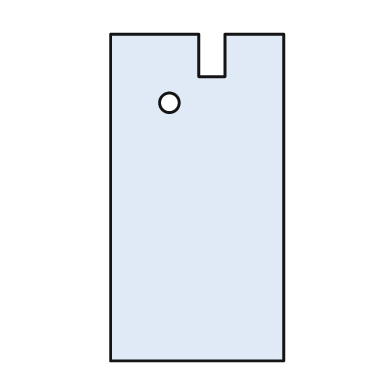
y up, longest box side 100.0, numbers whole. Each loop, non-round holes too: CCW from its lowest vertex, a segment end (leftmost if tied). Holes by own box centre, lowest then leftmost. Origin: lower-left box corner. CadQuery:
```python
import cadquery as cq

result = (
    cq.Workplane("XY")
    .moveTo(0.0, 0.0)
    .lineTo(53.0, 0.0)
    .lineTo(53.0, 100.0)
    .lineTo(35.0, 100.0)
    .lineTo(35.0, 87.0)
    .lineTo(27.0, 87.0)
    .lineTo(27.0, 100.0)
    .lineTo(0.0, 100.0)
    .close()
    .moveTo(18.0, 79.0)
    .circle(3.0)
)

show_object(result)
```